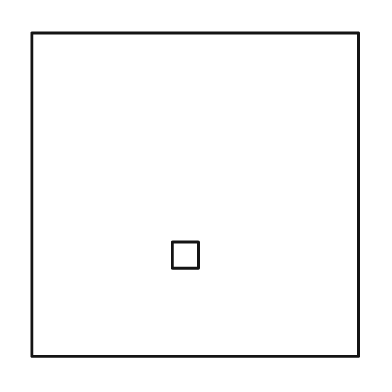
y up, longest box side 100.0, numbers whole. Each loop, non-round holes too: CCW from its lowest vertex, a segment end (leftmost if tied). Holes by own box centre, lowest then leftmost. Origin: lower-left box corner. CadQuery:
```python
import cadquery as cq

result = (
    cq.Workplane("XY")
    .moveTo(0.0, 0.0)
    .lineTo(100.0, 0.0)
    .lineTo(100.0, 99.0)
    .lineTo(0.0, 99.0)
    .close()
    .moveTo(43.0, 27.0)
    .lineTo(51.0, 27.0)
    .lineTo(51.0, 35.0)
    .lineTo(43.0, 35.0)
    .close()
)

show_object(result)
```